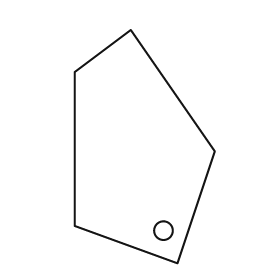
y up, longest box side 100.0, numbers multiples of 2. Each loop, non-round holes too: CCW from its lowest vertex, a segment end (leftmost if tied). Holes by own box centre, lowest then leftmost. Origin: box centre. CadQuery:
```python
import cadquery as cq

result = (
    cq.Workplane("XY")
    .moveTo(14.0, -50.0)
    .lineTo(30.0, -2.0)
    .lineTo(-6.0, 50.0)
    .lineTo(-30.0, 32.0)
    .lineTo(-30.0, -34.0)
    .close()
    .moveTo(8.0, -36.0)
    .circle(4.0)
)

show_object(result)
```